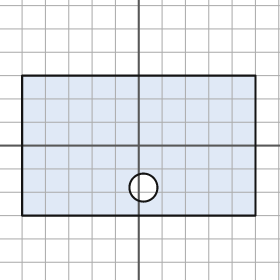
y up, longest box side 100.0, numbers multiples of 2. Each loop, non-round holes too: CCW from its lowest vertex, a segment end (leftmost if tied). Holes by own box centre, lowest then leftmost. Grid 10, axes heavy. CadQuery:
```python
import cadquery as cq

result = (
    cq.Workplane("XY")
    .moveTo(-50.0, -30.0)
    .lineTo(50.0, -30.0)
    .lineTo(50.0, 30.0)
    .lineTo(-50.0, 30.0)
    .close()
    .moveTo(2.0, -18.0)
    .circle(6.0)
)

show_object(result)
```